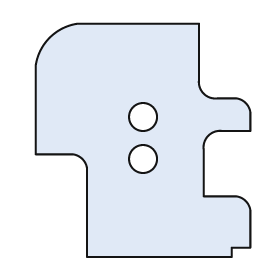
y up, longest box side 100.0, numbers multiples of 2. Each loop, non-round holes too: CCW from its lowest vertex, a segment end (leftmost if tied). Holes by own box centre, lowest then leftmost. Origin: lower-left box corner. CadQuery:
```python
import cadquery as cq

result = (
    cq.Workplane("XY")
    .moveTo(22.0, 0.0)
    .lineTo(84.0, 0.0)
    .lineTo(84.0, 4.0)
    .lineTo(92.0, 4.0)
    .lineTo(92.0, 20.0)
    .threePointArc((90.0, 24.0), (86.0, 26.0))
    .lineTo(72.0, 26.0)
    .lineTo(72.0, 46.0)
    .threePointArc((74.0, 52.0), (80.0, 54.0))
    .lineTo(92.0, 54.0)
    .lineTo(92.0, 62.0)
    .threePointArc((90.0, 66.0), (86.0, 68.0))
    .lineTo(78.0, 68.0)
    .threePointArc((72.0, 70.0), (70.0, 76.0))
    .lineTo(70.0, 100.0)
    .lineTo(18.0, 100.0)
    .threePointArc((6.0, 94.0), (0.0, 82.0))
    .lineTo(0.0, 44.0)
    .lineTo(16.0, 44.0)
    .threePointArc((20.0, 42.0), (22.0, 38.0))
    .close()
    .moveTo(46.0, 42.0)
    .circle(6.0)
    .moveTo(46.0, 60.0)
    .circle(6.0)
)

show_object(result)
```